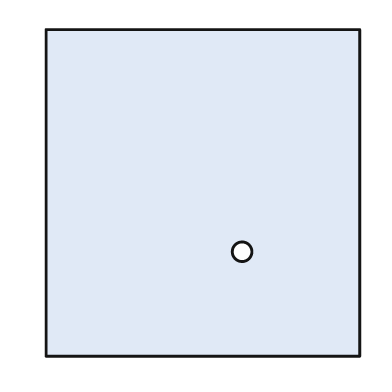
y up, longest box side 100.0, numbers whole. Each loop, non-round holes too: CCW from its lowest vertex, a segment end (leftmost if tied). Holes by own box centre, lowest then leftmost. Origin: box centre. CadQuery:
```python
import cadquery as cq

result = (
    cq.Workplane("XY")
    .moveTo(-48.0, -50.0)
    .lineTo(48.0, -50.0)
    .lineTo(48.0, 50.0)
    .lineTo(-48.0, 50.0)
    .close()
    .moveTo(12.0, -18.0)
    .circle(3.0)
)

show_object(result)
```